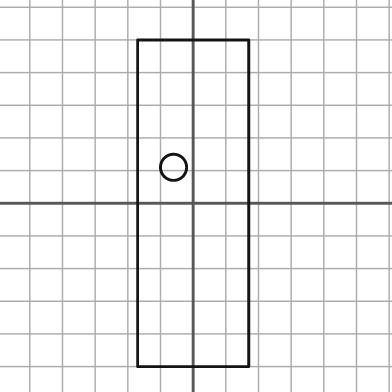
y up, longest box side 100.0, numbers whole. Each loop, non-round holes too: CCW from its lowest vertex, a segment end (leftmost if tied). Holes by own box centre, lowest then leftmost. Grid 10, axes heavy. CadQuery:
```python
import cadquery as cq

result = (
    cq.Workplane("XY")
    .moveTo(-17.0, -50.0)
    .lineTo(17.0, -50.0)
    .lineTo(17.0, 50.0)
    .lineTo(-17.0, 50.0)
    .close()
    .moveTo(-6.0, 11.0)
    .circle(4.0)
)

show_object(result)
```